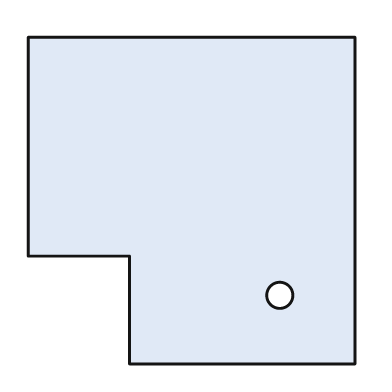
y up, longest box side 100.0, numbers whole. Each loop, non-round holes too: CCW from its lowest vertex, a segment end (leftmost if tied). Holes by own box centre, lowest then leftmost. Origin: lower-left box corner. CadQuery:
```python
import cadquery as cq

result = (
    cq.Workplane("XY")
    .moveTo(31.0, 0.0)
    .lineTo(100.0, 0.0)
    .lineTo(100.0, 100.0)
    .lineTo(0.0, 100.0)
    .lineTo(0.0, 33.0)
    .lineTo(31.0, 33.0)
    .close()
    .moveTo(77.0, 21.0)
    .circle(4.0)
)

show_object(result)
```